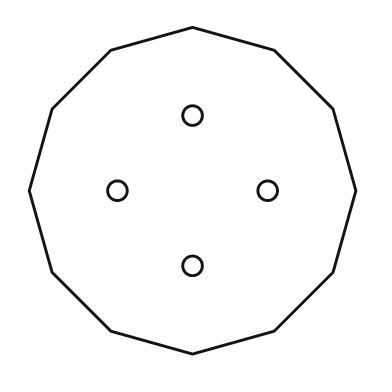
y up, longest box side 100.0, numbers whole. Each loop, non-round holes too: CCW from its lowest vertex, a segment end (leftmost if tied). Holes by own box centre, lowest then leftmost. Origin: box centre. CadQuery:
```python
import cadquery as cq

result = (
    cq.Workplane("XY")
    .moveTo(0.0, -50.0)
    .lineTo(25.0, -43.0)
    .lineTo(43.0, -25.0)
    .lineTo(50.0, 0.0)
    .lineTo(43.0, 25.0)
    .lineTo(25.0, 43.0)
    .lineTo(0.0, 50.0)
    .lineTo(-25.0, 43.0)
    .lineTo(-43.0, 25.0)
    .lineTo(-50.0, 0.0)
    .lineTo(-43.0, -25.0)
    .lineTo(-25.0, -43.0)
    .close()
    .moveTo(0.0, -23.0)
    .circle(3.0)
    .moveTo(-23.0, 0.0)
    .circle(3.0)
    .moveTo(23.0, 0.0)
    .circle(3.0)
    .moveTo(0.0, 23.0)
    .circle(3.0)
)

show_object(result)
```